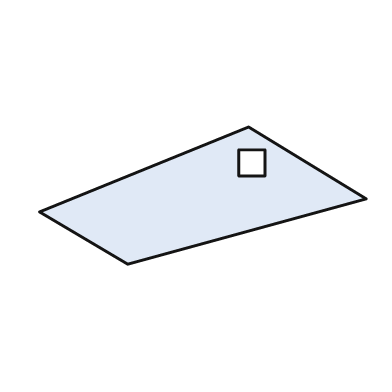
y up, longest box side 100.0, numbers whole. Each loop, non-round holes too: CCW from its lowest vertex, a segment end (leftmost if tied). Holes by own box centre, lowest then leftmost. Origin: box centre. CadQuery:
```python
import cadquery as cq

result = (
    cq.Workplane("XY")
    .moveTo(-23.0, -21.0)
    .lineTo(50.0, -1.0)
    .lineTo(14.0, 21.0)
    .lineTo(-50.0, -5.0)
    .close()
    .moveTo(11.0, 6.0)
    .lineTo(19.0, 6.0)
    .lineTo(19.0, 14.0)
    .lineTo(11.0, 14.0)
    .close()
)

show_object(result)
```